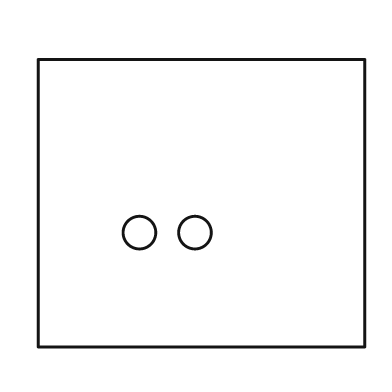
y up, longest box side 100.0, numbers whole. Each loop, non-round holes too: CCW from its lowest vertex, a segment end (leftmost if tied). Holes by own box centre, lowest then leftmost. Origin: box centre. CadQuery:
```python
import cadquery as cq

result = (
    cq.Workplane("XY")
    .moveTo(-50.0, -44.0)
    .lineTo(50.0, -44.0)
    .lineTo(50.0, 44.0)
    .lineTo(-50.0, 44.0)
    .close()
    .moveTo(-19.0, -9.0)
    .circle(5.0)
    .moveTo(-2.0, -9.0)
    .circle(5.0)
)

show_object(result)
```